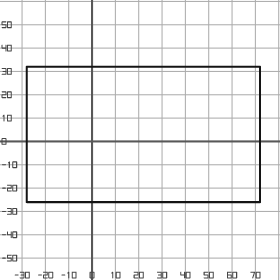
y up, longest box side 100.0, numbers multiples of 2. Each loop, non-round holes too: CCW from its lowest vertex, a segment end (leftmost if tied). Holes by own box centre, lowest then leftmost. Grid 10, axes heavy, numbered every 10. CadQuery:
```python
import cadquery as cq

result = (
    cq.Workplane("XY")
    .moveTo(-28.0, -26.0)
    .lineTo(72.0, -26.0)
    .lineTo(72.0, 32.0)
    .lineTo(-28.0, 32.0)
    .close()
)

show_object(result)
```